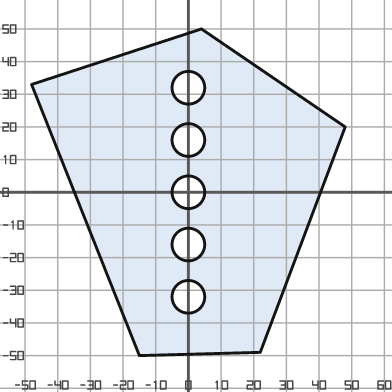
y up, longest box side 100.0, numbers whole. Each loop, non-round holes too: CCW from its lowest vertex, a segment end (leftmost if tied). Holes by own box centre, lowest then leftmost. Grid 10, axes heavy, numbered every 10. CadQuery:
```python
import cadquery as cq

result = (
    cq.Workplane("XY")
    .moveTo(-15.0, -50.0)
    .lineTo(22.0, -49.0)
    .lineTo(48.0, 20.0)
    .lineTo(4.0, 50.0)
    .lineTo(-48.0, 33.0)
    .close()
    .moveTo(0.0, -32.0)
    .circle(5.0)
    .moveTo(0.0, -16.0)
    .circle(5.0)
    .moveTo(0.0, 0.0)
    .circle(5.0)
    .moveTo(0.0, 16.0)
    .circle(5.0)
    .moveTo(0.0, 32.0)
    .circle(5.0)
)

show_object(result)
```